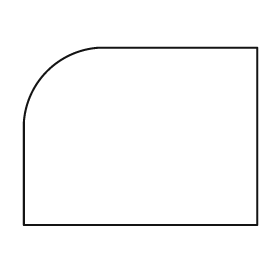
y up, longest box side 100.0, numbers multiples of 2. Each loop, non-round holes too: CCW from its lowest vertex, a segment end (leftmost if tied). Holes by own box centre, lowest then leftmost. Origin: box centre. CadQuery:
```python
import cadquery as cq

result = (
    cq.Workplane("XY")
    .moveTo(-50.0, -38.0)
    .lineTo(50.0, -38.0)
    .lineTo(50.0, 38.0)
    .lineTo(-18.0, 38.0)
    .threePointArc((-40.0, 28.0), (-50.0, 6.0))
    .close()
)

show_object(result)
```